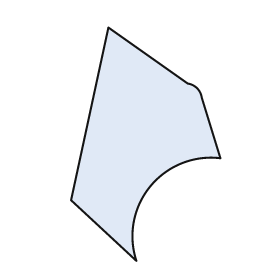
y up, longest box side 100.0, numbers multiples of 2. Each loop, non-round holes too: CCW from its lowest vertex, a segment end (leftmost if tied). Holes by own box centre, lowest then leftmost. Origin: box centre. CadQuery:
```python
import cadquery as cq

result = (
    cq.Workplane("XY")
    .moveTo(-4.0, -50.0)
    .threePointArc((2.0, -18.0), (32.0, -6.0))
    .lineTo(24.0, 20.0)
    .threePointArc((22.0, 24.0), (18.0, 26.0))
    .lineTo(-16.0, 50.0)
    .lineTo(-32.0, -24.0)
    .close()
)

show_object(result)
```